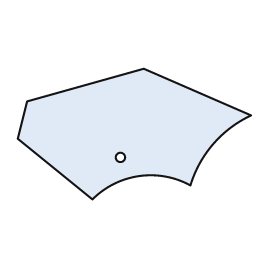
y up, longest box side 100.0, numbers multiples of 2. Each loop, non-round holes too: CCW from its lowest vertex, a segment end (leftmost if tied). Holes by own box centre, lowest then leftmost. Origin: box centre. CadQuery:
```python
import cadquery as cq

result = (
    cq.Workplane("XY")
    .moveTo(-18.0, -28.0)
    .threePointArc((2.0, -18.0), (24.0, -22.0))
    .threePointArc((34.0, -4.0), (50.0, 8.0))
    .lineTo(4.0, 28.0)
    .lineTo(-46.0, 14.0)
    .lineTo(-50.0, -2.0)
    .close()
    .moveTo(-6.0, -10.0)
    .circle(2.0)
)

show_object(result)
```